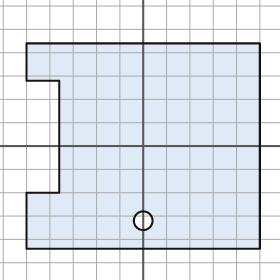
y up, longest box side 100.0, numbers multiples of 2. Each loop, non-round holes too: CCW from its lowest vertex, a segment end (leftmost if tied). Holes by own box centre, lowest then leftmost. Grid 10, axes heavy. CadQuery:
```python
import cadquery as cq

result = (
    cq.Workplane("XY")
    .moveTo(-50.0, -44.0)
    .lineTo(50.0, -44.0)
    .lineTo(50.0, 44.0)
    .lineTo(-50.0, 44.0)
    .lineTo(-50.0, 28.0)
    .lineTo(-36.0, 28.0)
    .lineTo(-36.0, -20.0)
    .lineTo(-50.0, -20.0)
    .close()
    .moveTo(0.0, -32.0)
    .circle(4.0)
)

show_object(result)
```